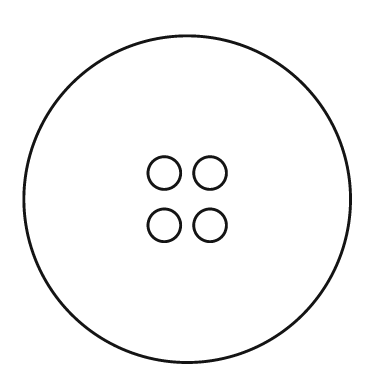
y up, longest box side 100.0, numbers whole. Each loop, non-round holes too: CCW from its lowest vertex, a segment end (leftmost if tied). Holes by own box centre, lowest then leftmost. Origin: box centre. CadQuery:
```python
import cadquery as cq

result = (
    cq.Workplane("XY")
    .moveTo(0.0, 0.0)
    .circle(50.0)
    .moveTo(-7.0, -8.0)
    .circle(5.0)
    .moveTo(7.0, -8.0)
    .circle(5.0)
    .moveTo(-7.0, 8.0)
    .circle(5.0)
    .moveTo(7.0, 8.0)
    .circle(5.0)
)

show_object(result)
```